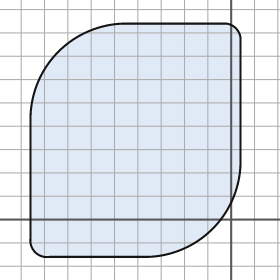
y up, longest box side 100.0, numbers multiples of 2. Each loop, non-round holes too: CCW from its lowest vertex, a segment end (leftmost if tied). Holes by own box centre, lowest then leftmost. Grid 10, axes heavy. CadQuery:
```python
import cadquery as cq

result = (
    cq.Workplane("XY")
    .moveTo(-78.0, -16.0)
    .lineTo(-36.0, -16.0)
    .threePointArc((-8.0, -4.0), (4.0, 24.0))
    .lineTo(4.0, 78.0)
    .threePointArc((2.0, 82.0), (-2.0, 84.0))
    .lineTo(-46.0, 84.0)
    .threePointArc((-74.0, 72.0), (-86.0, 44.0))
    .lineTo(-86.0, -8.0)
    .threePointArc((-84.0, -14.0), (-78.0, -16.0))
    .close()
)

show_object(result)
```